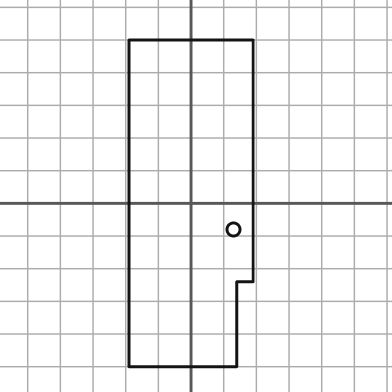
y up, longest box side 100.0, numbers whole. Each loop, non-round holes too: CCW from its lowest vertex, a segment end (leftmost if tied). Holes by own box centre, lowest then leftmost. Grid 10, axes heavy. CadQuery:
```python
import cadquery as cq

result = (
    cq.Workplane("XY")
    .moveTo(-19.0, -50.0)
    .lineTo(14.0, -50.0)
    .lineTo(14.0, -24.0)
    .lineTo(19.0, -24.0)
    .lineTo(19.0, 50.0)
    .lineTo(-19.0, 50.0)
    .close()
    .moveTo(13.0, -8.0)
    .circle(2.0)
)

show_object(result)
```